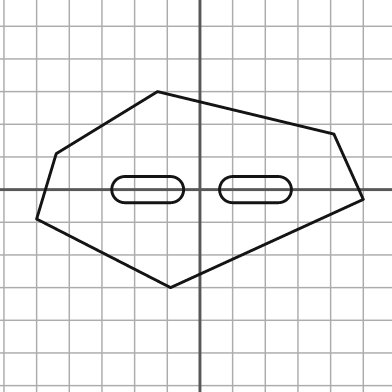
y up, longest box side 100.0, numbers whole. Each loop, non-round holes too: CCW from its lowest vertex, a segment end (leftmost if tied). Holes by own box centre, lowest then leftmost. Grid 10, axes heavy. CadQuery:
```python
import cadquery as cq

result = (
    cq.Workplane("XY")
    .moveTo(-9.0, -30.0)
    .lineTo(50.0, -3.0)
    .lineTo(41.0, 17.0)
    .lineTo(-13.0, 30.0)
    .lineTo(-44.0, 11.0)
    .lineTo(-50.0, -9.0)
    .close()
    .moveTo(-23.0, -4.0)
    .lineTo(-9.0, -4.0)
    .threePointArc((-5.0, 0.0), (-9.0, 4.0))
    .lineTo(-23.0, 4.0)
    .threePointArc((-27.0, 0.0), (-23.0, -4.0))
    .close()
    .moveTo(10.0, -4.0)
    .lineTo(24.0, -4.0)
    .threePointArc((28.0, 0.0), (24.0, 4.0))
    .lineTo(10.0, 4.0)
    .threePointArc((6.0, 0.0), (10.0, -4.0))
    .close()
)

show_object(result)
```